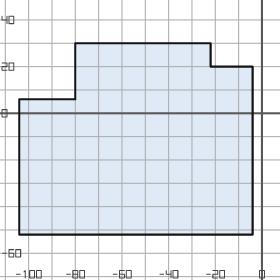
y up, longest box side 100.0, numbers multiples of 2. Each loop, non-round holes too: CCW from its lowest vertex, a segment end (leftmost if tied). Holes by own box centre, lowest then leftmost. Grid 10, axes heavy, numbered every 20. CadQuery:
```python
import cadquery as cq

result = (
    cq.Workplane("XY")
    .moveTo(-104.0, -52.0)
    .lineTo(-4.0, -52.0)
    .lineTo(-4.0, 20.0)
    .lineTo(-22.0, 20.0)
    .lineTo(-22.0, 30.0)
    .lineTo(-80.0, 30.0)
    .lineTo(-80.0, 6.0)
    .lineTo(-104.0, 6.0)
    .close()
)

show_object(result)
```